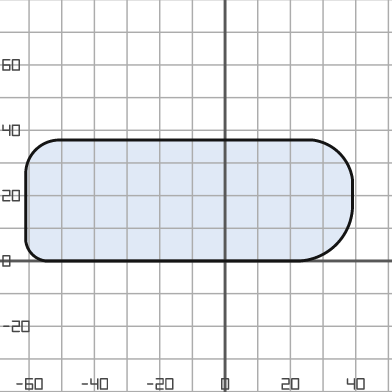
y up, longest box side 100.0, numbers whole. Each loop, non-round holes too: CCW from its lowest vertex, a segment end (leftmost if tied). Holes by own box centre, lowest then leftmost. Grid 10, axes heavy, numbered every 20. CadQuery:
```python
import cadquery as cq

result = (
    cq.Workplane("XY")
    .moveTo(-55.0, 0.0)
    .lineTo(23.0, 0.0)
    .threePointArc((34.0, 5.0), (39.0, 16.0))
    .lineTo(39.0, 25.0)
    .threePointArc((35.0, 33.0), (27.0, 37.0))
    .lineTo(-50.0, 37.0)
    .threePointArc((-58.0, 34.0), (-61.0, 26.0))
    .lineTo(-61.0, 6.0)
    .threePointArc((-59.0, 2.0), (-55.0, 0.0))
    .close()
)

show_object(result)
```